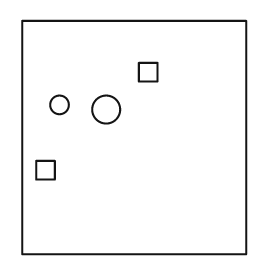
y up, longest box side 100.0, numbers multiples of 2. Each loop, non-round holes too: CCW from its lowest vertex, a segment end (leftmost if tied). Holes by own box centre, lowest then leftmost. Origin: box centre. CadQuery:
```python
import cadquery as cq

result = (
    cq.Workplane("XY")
    .moveTo(-48.0, -50.0)
    .lineTo(48.0, -50.0)
    .lineTo(48.0, 50.0)
    .lineTo(-48.0, 50.0)
    .close()
    .moveTo(-42.0, -18.0)
    .lineTo(-34.0, -18.0)
    .lineTo(-34.0, -10.0)
    .lineTo(-42.0, -10.0)
    .close()
    .moveTo(-12.0, 12.0)
    .circle(6.0)
    .moveTo(-32.0, 14.0)
    .circle(4.0)
    .moveTo(2.0, 24.0)
    .lineTo(10.0, 24.0)
    .lineTo(10.0, 32.0)
    .lineTo(2.0, 32.0)
    .close()
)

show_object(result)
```